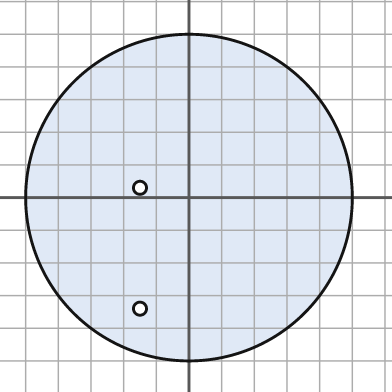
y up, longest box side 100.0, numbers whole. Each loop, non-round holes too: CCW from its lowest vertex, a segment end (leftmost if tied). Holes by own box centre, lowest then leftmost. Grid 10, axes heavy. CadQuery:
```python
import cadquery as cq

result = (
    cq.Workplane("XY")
    .moveTo(0.0, 0.0)
    .circle(50.0)
    .moveTo(-15.0, -34.0)
    .circle(2.0)
    .moveTo(-15.0, 3.0)
    .circle(2.0)
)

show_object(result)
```